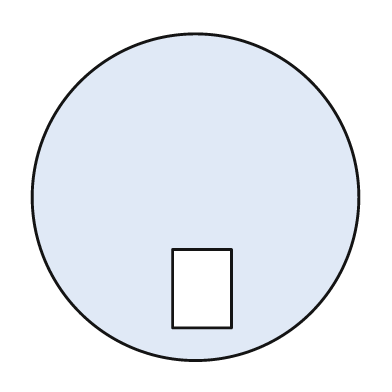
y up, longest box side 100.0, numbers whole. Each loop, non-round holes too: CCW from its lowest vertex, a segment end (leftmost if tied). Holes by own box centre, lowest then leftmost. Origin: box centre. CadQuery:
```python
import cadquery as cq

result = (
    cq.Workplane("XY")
    .moveTo(0.0, 0.0)
    .circle(50.0)
    .moveTo(-7.0, -40.0)
    .lineTo(11.0, -40.0)
    .lineTo(11.0, -16.0)
    .lineTo(-7.0, -16.0)
    .close()
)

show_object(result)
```